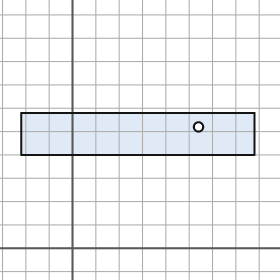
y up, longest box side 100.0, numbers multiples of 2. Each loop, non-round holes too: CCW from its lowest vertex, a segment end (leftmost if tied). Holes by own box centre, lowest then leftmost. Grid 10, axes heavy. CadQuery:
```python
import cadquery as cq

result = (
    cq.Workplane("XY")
    .moveTo(-22.0, 40.0)
    .lineTo(78.0, 40.0)
    .lineTo(78.0, 58.0)
    .lineTo(-22.0, 58.0)
    .close()
    .moveTo(54.0, 52.0)
    .circle(2.0)
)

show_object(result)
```